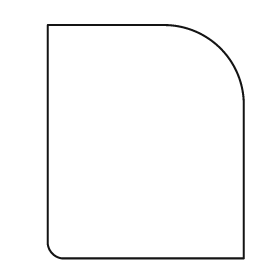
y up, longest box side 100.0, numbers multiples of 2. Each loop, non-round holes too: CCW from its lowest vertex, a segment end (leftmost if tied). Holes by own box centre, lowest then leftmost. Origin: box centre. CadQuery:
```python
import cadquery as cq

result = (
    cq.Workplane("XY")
    .moveTo(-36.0, -50.0)
    .lineTo(42.0, -50.0)
    .lineTo(42.0, 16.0)
    .threePointArc((32.0, 40.0), (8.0, 50.0))
    .lineTo(-42.0, 50.0)
    .lineTo(-42.0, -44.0)
    .threePointArc((-40.0, -48.0), (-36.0, -50.0))
    .close()
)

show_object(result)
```